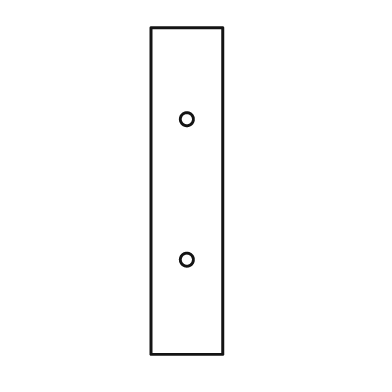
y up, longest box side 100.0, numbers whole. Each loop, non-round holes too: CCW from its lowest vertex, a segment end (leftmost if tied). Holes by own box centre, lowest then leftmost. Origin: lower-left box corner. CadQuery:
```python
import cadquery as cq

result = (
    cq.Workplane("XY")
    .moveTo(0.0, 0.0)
    .lineTo(22.0, 0.0)
    .lineTo(22.0, 100.0)
    .lineTo(0.0, 100.0)
    .close()
    .moveTo(11.0, 29.0)
    .circle(2.0)
    .moveTo(11.0, 72.0)
    .circle(2.0)
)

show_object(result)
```